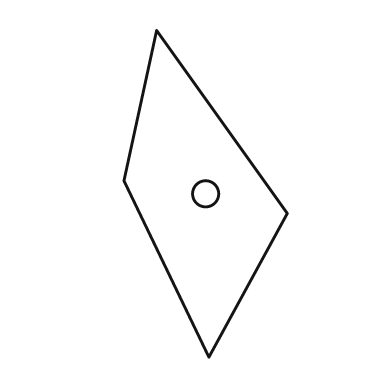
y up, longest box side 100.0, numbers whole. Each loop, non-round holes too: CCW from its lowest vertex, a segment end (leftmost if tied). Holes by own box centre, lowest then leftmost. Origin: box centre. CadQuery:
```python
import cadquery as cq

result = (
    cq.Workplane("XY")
    .moveTo(1.0, -50.0)
    .lineTo(25.0, -6.0)
    .lineTo(-15.0, 50.0)
    .lineTo(-25.0, 4.0)
    .close()
    .moveTo(0.0, 0.0)
    .circle(4.0)
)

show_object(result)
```